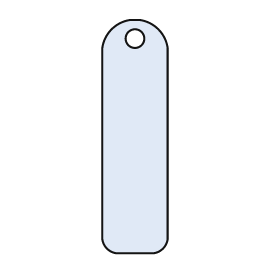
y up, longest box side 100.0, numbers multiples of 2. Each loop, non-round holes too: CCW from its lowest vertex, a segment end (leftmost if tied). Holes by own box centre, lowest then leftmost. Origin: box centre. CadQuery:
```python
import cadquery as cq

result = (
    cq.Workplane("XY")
    .moveTo(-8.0, -50.0)
    .lineTo(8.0, -50.0)
    .threePointArc((12.0, -48.0), (14.0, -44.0))
    .lineTo(14.0, 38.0)
    .threePointArc((10.0, 46.0), (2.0, 50.0))
    .lineTo(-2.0, 50.0)
    .threePointArc((-10.0, 46.0), (-14.0, 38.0))
    .lineTo(-14.0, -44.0)
    .threePointArc((-12.0, -48.0), (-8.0, -50.0))
    .close()
    .moveTo(0.0, 42.0)
    .circle(4.0)
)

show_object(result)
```